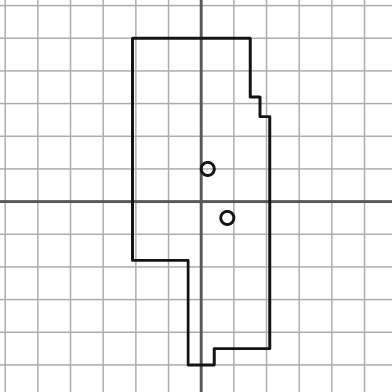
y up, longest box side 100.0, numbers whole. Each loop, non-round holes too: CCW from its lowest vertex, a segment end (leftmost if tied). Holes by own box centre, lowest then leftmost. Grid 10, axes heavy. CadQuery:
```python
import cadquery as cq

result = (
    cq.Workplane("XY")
    .moveTo(-4.0, -50.0)
    .lineTo(4.0, -50.0)
    .lineTo(4.0, -45.0)
    .lineTo(21.0, -45.0)
    .lineTo(21.0, 26.0)
    .lineTo(18.0, 26.0)
    .lineTo(18.0, 32.0)
    .lineTo(15.0, 32.0)
    .lineTo(15.0, 50.0)
    .lineTo(-21.0, 50.0)
    .lineTo(-21.0, -18.0)
    .lineTo(-4.0, -18.0)
    .close()
    .moveTo(8.0, -5.0)
    .circle(2.0)
    .moveTo(2.0, 10.0)
    .circle(2.0)
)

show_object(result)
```